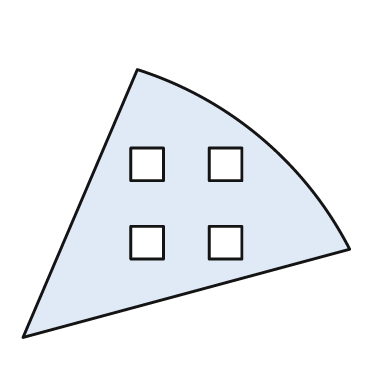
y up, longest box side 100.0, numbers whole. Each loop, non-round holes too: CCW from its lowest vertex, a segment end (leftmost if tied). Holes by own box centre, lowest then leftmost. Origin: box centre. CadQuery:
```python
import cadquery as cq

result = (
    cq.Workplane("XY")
    .moveTo(-50.0, -41.0)
    .lineTo(50.0, -14.0)
    .threePointArc((23.0, 20.0), (-15.0, 41.0))
    .close()
    .moveTo(-17.0, -17.0)
    .lineTo(-7.0, -17.0)
    .lineTo(-7.0, -7.0)
    .lineTo(-17.0, -7.0)
    .close()
    .moveTo(7.0, -17.0)
    .lineTo(17.0, -17.0)
    .lineTo(17.0, -7.0)
    .lineTo(7.0, -7.0)
    .close()
    .moveTo(-17.0, 7.0)
    .lineTo(-7.0, 7.0)
    .lineTo(-7.0, 17.0)
    .lineTo(-17.0, 17.0)
    .close()
    .moveTo(7.0, 7.0)
    .lineTo(17.0, 7.0)
    .lineTo(17.0, 17.0)
    .lineTo(7.0, 17.0)
    .close()
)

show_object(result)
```